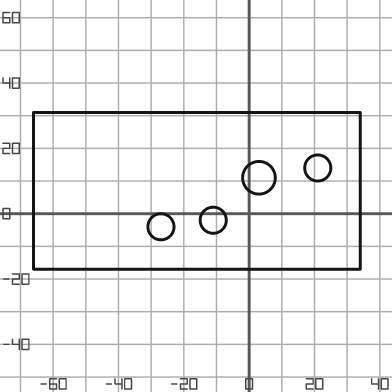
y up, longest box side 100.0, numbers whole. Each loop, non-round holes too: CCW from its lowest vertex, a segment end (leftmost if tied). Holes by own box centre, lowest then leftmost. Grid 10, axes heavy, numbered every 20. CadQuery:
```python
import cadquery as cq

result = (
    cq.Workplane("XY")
    .moveTo(-66.0, -17.0)
    .lineTo(34.0, -17.0)
    .lineTo(34.0, 31.0)
    .lineTo(-66.0, 31.0)
    .close()
    .moveTo(-27.0, -4.0)
    .circle(4.0)
    .moveTo(-11.0, -2.0)
    .circle(4.0)
    .moveTo(3.0, 11.0)
    .circle(5.0)
    .moveTo(21.0, 14.0)
    .circle(4.0)
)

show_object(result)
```